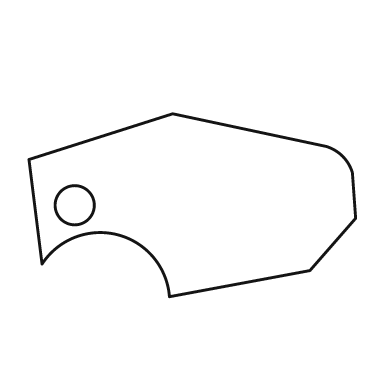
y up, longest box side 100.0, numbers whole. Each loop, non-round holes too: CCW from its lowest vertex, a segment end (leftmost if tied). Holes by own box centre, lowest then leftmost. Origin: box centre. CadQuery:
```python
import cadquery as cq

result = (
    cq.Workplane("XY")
    .moveTo(-7.0, -28.0)
    .lineTo(36.0, -20.0)
    .lineTo(50.0, -4.0)
    .lineTo(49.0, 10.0)
    .threePointArc((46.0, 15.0), (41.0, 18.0))
    .lineTo(-6.0, 28.0)
    .lineTo(-50.0, 14.0)
    .lineTo(-46.0, -18.0)
    .threePointArc((-23.0, -9.0), (-7.0, -28.0))
    .close()
    .moveTo(-36.0, 0.0)
    .circle(6.0)
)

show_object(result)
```